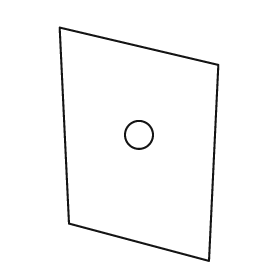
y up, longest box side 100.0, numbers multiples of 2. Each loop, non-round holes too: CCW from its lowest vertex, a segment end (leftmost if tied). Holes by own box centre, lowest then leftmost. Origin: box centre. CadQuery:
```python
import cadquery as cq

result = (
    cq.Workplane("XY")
    .moveTo(30.0, -50.0)
    .lineTo(34.0, 34.0)
    .lineTo(-34.0, 50.0)
    .lineTo(-30.0, -34.0)
    .close()
    .moveTo(0.0, 4.0)
    .circle(6.0)
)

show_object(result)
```